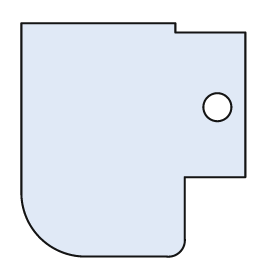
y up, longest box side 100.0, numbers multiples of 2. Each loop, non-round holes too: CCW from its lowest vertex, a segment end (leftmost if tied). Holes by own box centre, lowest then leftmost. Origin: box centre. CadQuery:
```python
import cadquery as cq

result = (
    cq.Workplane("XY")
    .moveTo(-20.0, -50.0)
    .lineTo(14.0, -50.0)
    .threePointArc((20.0, -48.0), (22.0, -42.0))
    .lineTo(22.0, -16.0)
    .lineTo(48.0, -16.0)
    .lineTo(48.0, 46.0)
    .lineTo(18.0, 46.0)
    .lineTo(18.0, 50.0)
    .lineTo(-48.0, 50.0)
    .lineTo(-48.0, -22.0)
    .threePointArc((-40.0, -42.0), (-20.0, -50.0))
    .close()
    .moveTo(36.0, 14.0)
    .circle(6.0)
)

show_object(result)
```